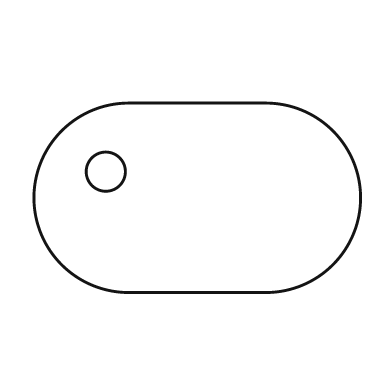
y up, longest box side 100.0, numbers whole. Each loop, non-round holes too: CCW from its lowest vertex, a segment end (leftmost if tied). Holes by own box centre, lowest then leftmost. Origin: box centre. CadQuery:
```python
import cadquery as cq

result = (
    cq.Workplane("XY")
    .moveTo(-21.0, -29.0)
    .lineTo(21.0, -29.0)
    .threePointArc((50.0, 0.0), (21.0, 29.0))
    .lineTo(-21.0, 29.0)
    .threePointArc((-50.0, 0.0), (-21.0, -29.0))
    .close()
    .moveTo(-28.0, 8.0)
    .circle(6.0)
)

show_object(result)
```